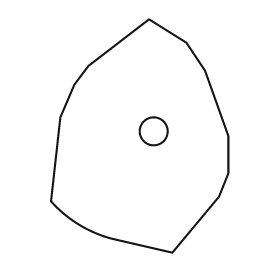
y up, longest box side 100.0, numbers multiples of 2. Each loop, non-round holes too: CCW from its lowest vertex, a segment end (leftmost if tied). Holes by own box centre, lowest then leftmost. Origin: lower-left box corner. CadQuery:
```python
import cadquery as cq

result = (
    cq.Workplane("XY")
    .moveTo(52.0, 0.0)
    .lineTo(72.0, 24.0)
    .lineTo(76.0, 34.0)
    .lineTo(76.0, 50.0)
    .lineTo(66.0, 78.0)
    .lineTo(58.0, 90.0)
    .lineTo(42.0, 100.0)
    .lineTo(16.0, 80.0)
    .lineTo(10.0, 72.0)
    .lineTo(4.0, 58.0)
    .lineTo(0.0, 22.0)
    .threePointArc((12.0, 12.0), (26.0, 6.0))
    .close()
    .moveTo(44.0, 52.0)
    .circle(6.0)
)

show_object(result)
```